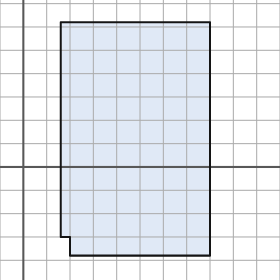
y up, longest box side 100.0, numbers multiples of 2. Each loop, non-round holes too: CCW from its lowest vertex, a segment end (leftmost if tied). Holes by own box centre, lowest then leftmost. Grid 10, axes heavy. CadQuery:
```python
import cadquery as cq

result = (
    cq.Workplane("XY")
    .moveTo(20.0, -38.0)
    .lineTo(80.0, -38.0)
    .lineTo(80.0, 62.0)
    .lineTo(16.0, 62.0)
    .lineTo(16.0, -30.0)
    .lineTo(20.0, -30.0)
    .close()
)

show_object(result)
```